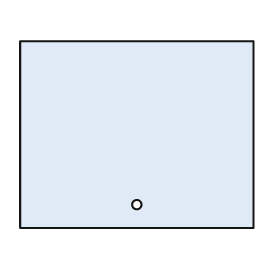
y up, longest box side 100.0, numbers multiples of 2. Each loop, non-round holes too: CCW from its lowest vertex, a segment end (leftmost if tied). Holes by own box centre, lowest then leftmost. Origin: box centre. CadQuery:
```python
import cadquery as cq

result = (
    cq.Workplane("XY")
    .moveTo(-50.0, -40.0)
    .lineTo(50.0, -40.0)
    .lineTo(50.0, 40.0)
    .lineTo(-50.0, 40.0)
    .close()
    .moveTo(0.0, -30.0)
    .circle(2.0)
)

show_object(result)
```